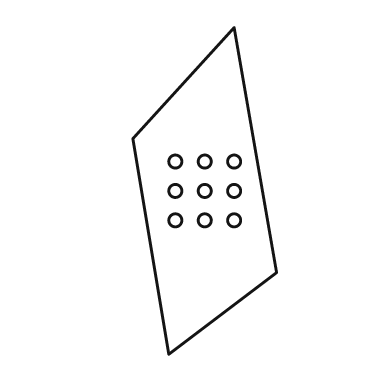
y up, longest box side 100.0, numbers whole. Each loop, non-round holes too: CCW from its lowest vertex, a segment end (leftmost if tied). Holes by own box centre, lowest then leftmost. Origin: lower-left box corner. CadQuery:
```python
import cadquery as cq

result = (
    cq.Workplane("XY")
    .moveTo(11.0, 0.0)
    .lineTo(44.0, 25.0)
    .lineTo(31.0, 100.0)
    .lineTo(0.0, 66.0)
    .close()
    .moveTo(13.0, 41.0)
    .circle(2.0)
    .moveTo(22.0, 41.0)
    .circle(2.0)
    .moveTo(31.0, 41.0)
    .circle(2.0)
    .moveTo(13.0, 50.0)
    .circle(2.0)
    .moveTo(22.0, 50.0)
    .circle(2.0)
    .moveTo(31.0, 50.0)
    .circle(2.0)
    .moveTo(13.0, 59.0)
    .circle(2.0)
    .moveTo(22.0, 59.0)
    .circle(2.0)
    .moveTo(31.0, 59.0)
    .circle(2.0)
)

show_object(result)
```